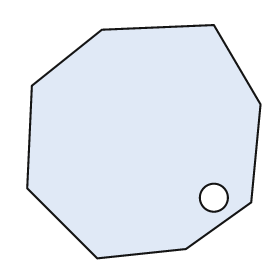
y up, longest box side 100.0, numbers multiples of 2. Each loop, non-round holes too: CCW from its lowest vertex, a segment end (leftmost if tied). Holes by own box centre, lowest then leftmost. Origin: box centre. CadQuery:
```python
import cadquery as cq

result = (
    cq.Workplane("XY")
    .moveTo(-20.0, -50.0)
    .lineTo(18.0, -46.0)
    .lineTo(46.0, -26.0)
    .lineTo(50.0, 16.0)
    .lineTo(30.0, 50.0)
    .lineTo(-18.0, 48.0)
    .lineTo(-48.0, 24.0)
    .lineTo(-50.0, -20.0)
    .close()
    .moveTo(30.0, -24.0)
    .circle(6.0)
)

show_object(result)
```